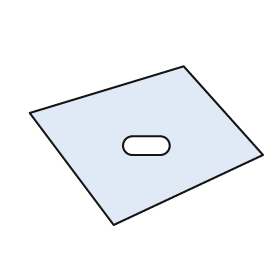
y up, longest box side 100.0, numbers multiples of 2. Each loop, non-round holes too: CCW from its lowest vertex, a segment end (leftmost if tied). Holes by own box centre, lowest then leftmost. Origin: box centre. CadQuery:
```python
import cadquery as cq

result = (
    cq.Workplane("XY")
    .moveTo(-14.0, -34.0)
    .lineTo(50.0, -4.0)
    .lineTo(16.0, 34.0)
    .lineTo(-50.0, 14.0)
    .close()
    .moveTo(-6.0, -4.0)
    .lineTo(6.0, -4.0)
    .threePointArc((10.0, 0.0), (6.0, 4.0))
    .lineTo(-6.0, 4.0)
    .threePointArc((-10.0, 0.0), (-6.0, -4.0))
    .close()
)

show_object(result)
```